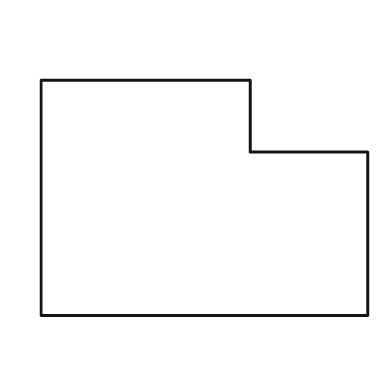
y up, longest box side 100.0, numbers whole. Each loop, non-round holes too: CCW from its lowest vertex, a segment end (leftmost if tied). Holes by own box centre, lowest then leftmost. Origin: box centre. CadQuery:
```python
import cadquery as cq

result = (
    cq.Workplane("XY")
    .moveTo(-50.0, -36.0)
    .lineTo(50.0, -36.0)
    .lineTo(50.0, 14.0)
    .lineTo(14.0, 14.0)
    .lineTo(14.0, 36.0)
    .lineTo(-50.0, 36.0)
    .close()
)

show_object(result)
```